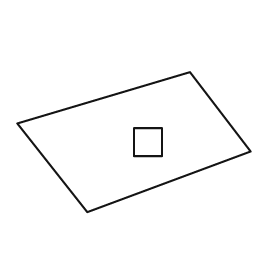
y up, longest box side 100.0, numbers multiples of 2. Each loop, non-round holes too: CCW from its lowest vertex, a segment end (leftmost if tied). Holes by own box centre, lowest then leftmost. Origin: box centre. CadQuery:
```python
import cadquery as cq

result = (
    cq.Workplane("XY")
    .moveTo(-20.0, -30.0)
    .lineTo(50.0, -4.0)
    .lineTo(24.0, 30.0)
    .lineTo(-50.0, 8.0)
    .close()
    .moveTo(0.0, -6.0)
    .lineTo(12.0, -6.0)
    .lineTo(12.0, 6.0)
    .lineTo(0.0, 6.0)
    .close()
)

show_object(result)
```